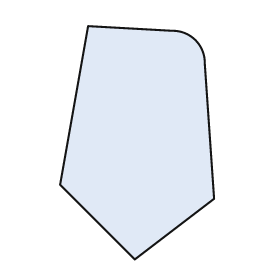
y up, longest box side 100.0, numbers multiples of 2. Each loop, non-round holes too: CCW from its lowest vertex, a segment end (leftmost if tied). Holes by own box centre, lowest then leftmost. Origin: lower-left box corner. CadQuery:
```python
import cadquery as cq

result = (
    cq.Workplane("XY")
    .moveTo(32.0, 0.0)
    .lineTo(66.0, 26.0)
    .lineTo(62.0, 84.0)
    .threePointArc((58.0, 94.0), (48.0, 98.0))
    .lineTo(12.0, 100.0)
    .lineTo(0.0, 32.0)
    .close()
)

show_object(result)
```